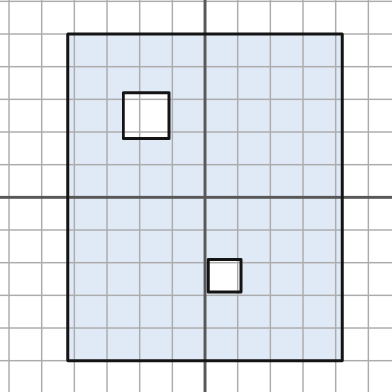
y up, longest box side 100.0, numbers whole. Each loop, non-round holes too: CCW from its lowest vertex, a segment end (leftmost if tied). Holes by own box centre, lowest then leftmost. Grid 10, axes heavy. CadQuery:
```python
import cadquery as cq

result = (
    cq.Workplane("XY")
    .moveTo(-42.0, -50.0)
    .lineTo(42.0, -50.0)
    .lineTo(42.0, 50.0)
    .lineTo(-42.0, 50.0)
    .close()
    .moveTo(1.0, -29.0)
    .lineTo(11.0, -29.0)
    .lineTo(11.0, -19.0)
    .lineTo(1.0, -19.0)
    .close()
    .moveTo(-25.0, 18.0)
    .lineTo(-11.0, 18.0)
    .lineTo(-11.0, 32.0)
    .lineTo(-25.0, 32.0)
    .close()
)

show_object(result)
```